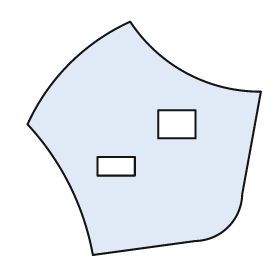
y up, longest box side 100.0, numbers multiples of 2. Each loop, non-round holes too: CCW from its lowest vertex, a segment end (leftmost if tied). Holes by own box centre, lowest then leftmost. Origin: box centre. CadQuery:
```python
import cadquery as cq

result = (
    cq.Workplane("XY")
    .moveTo(-22.0, -50.0)
    .lineTo(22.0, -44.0)
    .threePointArc((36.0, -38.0), (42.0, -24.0))
    .lineTo(50.0, 20.0)
    .threePointArc((18.0, 28.0), (-6.0, 50.0))
    .threePointArc((-32.0, 32.0), (-50.0, 6.0))
    .threePointArc((-32.0, -20.0), (-22.0, -50.0))
    .close()
    .moveTo(-20.0, -16.0)
    .lineTo(-4.0, -16.0)
    .lineTo(-4.0, -8.0)
    .lineTo(-20.0, -8.0)
    .close()
    .moveTo(6.0, 0.0)
    .lineTo(22.0, 0.0)
    .lineTo(22.0, 12.0)
    .lineTo(6.0, 12.0)
    .close()
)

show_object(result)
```